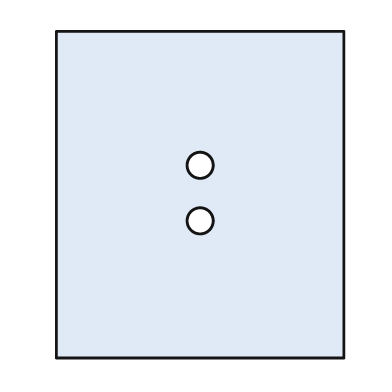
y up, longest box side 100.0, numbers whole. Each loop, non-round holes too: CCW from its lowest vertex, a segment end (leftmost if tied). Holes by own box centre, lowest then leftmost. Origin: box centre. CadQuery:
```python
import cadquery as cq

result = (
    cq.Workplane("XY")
    .moveTo(-44.0, -50.0)
    .lineTo(44.0, -50.0)
    .lineTo(44.0, 50.0)
    .lineTo(-44.0, 50.0)
    .close()
    .moveTo(0.0, -8.0)
    .circle(4.0)
    .moveTo(0.0, 9.0)
    .circle(4.0)
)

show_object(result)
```